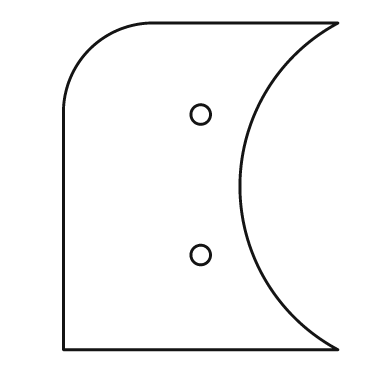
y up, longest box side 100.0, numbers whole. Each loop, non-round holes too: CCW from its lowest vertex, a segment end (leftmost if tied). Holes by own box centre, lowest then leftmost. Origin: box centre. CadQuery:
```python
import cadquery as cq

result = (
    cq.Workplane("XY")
    .moveTo(-42.0, -50.0)
    .lineTo(42.0, -50.0)
    .threePointArc((12.0, 0.0), (42.0, 50.0))
    .lineTo(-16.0, 50.0)
    .threePointArc((-34.0, 42.0), (-42.0, 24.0))
    .close()
    .moveTo(0.0, -21.0)
    .circle(3.0)
    .moveTo(0.0, 22.0)
    .circle(3.0)
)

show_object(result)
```